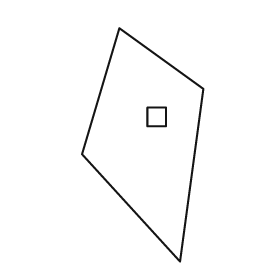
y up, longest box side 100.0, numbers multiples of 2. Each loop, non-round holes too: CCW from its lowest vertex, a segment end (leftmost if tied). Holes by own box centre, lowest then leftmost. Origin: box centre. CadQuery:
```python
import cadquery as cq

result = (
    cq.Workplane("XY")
    .moveTo(16.0, -50.0)
    .lineTo(26.0, 24.0)
    .lineTo(-10.0, 50.0)
    .lineTo(-26.0, -4.0)
    .close()
    .moveTo(2.0, 8.0)
    .lineTo(10.0, 8.0)
    .lineTo(10.0, 16.0)
    .lineTo(2.0, 16.0)
    .close()
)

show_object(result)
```